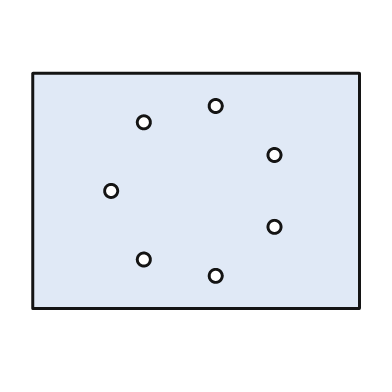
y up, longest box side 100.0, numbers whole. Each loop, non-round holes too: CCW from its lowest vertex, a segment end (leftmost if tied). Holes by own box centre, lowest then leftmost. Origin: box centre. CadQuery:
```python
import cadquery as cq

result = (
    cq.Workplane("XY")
    .moveTo(-50.0, -36.0)
    .lineTo(50.0, -36.0)
    .lineTo(50.0, 36.0)
    .lineTo(-50.0, 36.0)
    .close()
    .moveTo(6.0, -26.0)
    .circle(2.0)
    .moveTo(-16.0, -21.0)
    .circle(2.0)
    .moveTo(24.0, -11.0)
    .circle(2.0)
    .moveTo(-26.0, 0.0)
    .circle(2.0)
    .moveTo(24.0, 11.0)
    .circle(2.0)
    .moveTo(-16.0, 21.0)
    .circle(2.0)
    .moveTo(6.0, 26.0)
    .circle(2.0)
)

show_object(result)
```